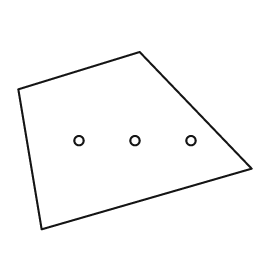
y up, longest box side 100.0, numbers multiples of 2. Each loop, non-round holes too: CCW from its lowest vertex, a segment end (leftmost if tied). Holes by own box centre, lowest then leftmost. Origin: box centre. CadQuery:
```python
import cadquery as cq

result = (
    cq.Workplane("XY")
    .moveTo(-40.0, -38.0)
    .lineTo(50.0, -12.0)
    .lineTo(2.0, 38.0)
    .lineTo(-50.0, 22.0)
    .close()
    .moveTo(-24.0, 0.0)
    .circle(2.0)
    .moveTo(0.0, 0.0)
    .circle(2.0)
    .moveTo(24.0, 0.0)
    .circle(2.0)
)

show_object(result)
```